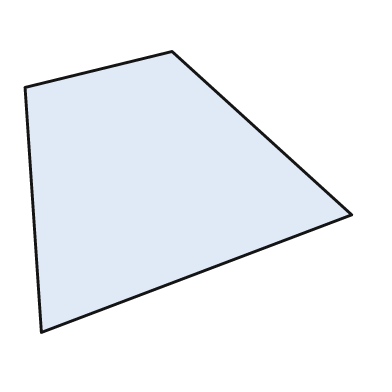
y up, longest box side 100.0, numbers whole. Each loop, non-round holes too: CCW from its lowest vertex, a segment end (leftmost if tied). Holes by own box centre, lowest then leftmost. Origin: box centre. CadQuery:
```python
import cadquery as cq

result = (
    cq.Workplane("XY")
    .moveTo(-45.0, -43.0)
    .lineTo(50.0, -7.0)
    .lineTo(-5.0, 43.0)
    .lineTo(-50.0, 32.0)
    .close()
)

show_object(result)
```